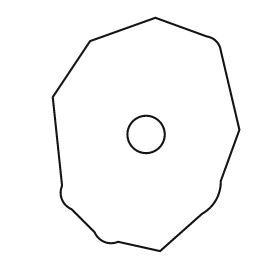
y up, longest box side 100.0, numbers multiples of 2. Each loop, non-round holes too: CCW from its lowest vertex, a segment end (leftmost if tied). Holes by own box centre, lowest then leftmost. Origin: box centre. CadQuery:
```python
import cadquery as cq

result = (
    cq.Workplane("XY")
    .moveTo(6.0, -50.0)
    .lineTo(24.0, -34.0)
    .threePointArc((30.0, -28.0), (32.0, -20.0))
    .lineTo(40.0, 2.0)
    .lineTo(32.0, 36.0)
    .threePointArc((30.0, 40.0), (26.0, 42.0))
    .lineTo(4.0, 50.0)
    .lineTo(-24.0, 40.0)
    .lineTo(-40.0, 16.0)
    .lineTo(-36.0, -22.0)
    .threePointArc((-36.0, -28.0), (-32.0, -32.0))
    .lineTo(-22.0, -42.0)
    .threePointArc((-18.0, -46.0), (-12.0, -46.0))
    .close()
    .moveTo(0.0, 0.0)
    .circle(8.0)
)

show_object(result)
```